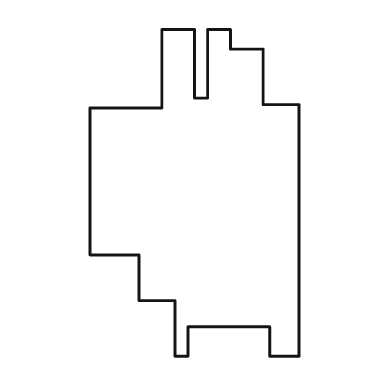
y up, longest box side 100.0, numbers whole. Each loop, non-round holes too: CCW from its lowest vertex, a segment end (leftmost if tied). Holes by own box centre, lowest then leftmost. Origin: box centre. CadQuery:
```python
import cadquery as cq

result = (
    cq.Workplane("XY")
    .moveTo(-6.0, -50.0)
    .lineTo(-2.0, -50.0)
    .lineTo(-2.0, -41.0)
    .lineTo(23.0, -41.0)
    .lineTo(23.0, -50.0)
    .lineTo(32.0, -50.0)
    .lineTo(32.0, 27.0)
    .lineTo(21.0, 27.0)
    .lineTo(21.0, 44.0)
    .lineTo(11.0, 44.0)
    .lineTo(11.0, 50.0)
    .lineTo(4.0, 50.0)
    .lineTo(4.0, 29.0)
    .lineTo(0.0, 29.0)
    .lineTo(0.0, 50.0)
    .lineTo(-10.0, 50.0)
    .lineTo(-10.0, 26.0)
    .lineTo(-32.0, 26.0)
    .lineTo(-32.0, -19.0)
    .lineTo(-17.0, -19.0)
    .lineTo(-17.0, -33.0)
    .lineTo(-6.0, -33.0)
    .close()
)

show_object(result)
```